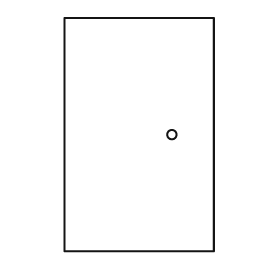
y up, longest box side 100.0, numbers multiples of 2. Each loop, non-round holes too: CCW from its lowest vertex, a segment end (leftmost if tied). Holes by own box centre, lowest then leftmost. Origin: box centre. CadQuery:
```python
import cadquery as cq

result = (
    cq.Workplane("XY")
    .moveTo(-32.0, -50.0)
    .lineTo(32.0, -50.0)
    .lineTo(32.0, 50.0)
    .lineTo(-32.0, 50.0)
    .close()
    .moveTo(14.0, 0.0)
    .circle(2.0)
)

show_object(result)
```